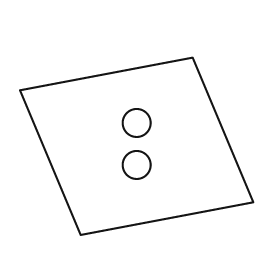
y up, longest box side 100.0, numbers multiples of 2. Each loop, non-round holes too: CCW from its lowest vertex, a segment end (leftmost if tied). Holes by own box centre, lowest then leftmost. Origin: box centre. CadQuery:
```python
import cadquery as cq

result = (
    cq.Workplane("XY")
    .moveTo(-24.0, -38.0)
    .lineTo(50.0, -24.0)
    .lineTo(24.0, 38.0)
    .lineTo(-50.0, 24.0)
    .close()
    .moveTo(0.0, -8.0)
    .circle(6.0)
    .moveTo(0.0, 10.0)
    .circle(6.0)
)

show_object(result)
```